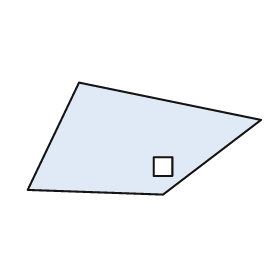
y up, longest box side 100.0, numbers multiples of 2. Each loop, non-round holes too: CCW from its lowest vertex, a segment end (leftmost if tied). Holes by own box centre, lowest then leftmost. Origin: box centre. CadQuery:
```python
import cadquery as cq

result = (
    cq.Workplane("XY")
    .moveTo(8.0, -24.0)
    .lineTo(50.0, 8.0)
    .lineTo(-28.0, 24.0)
    .lineTo(-50.0, -22.0)
    .close()
    .moveTo(4.0, -16.0)
    .lineTo(12.0, -16.0)
    .lineTo(12.0, -8.0)
    .lineTo(4.0, -8.0)
    .close()
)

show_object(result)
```